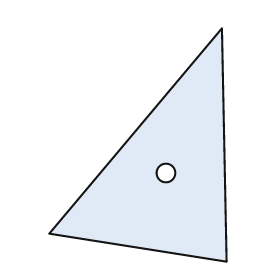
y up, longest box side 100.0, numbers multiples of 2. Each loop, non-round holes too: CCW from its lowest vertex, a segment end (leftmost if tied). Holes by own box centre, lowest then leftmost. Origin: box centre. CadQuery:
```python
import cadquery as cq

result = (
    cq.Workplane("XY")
    .moveTo(38.0, -50.0)
    .lineTo(36.0, 50.0)
    .lineTo(-38.0, -38.0)
    .close()
    .moveTo(12.0, -12.0)
    .circle(4.0)
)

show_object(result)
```